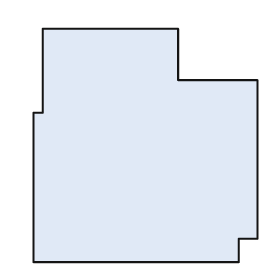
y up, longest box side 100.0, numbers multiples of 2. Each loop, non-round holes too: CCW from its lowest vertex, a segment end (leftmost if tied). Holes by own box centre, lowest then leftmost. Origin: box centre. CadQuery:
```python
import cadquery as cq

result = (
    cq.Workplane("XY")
    .moveTo(-48.0, -50.0)
    .lineTo(40.0, -50.0)
    .lineTo(40.0, -40.0)
    .lineTo(48.0, -40.0)
    .lineTo(48.0, 28.0)
    .lineTo(14.0, 28.0)
    .lineTo(14.0, 50.0)
    .lineTo(-44.0, 50.0)
    .lineTo(-44.0, 14.0)
    .lineTo(-48.0, 14.0)
    .close()
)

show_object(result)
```